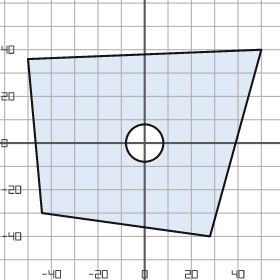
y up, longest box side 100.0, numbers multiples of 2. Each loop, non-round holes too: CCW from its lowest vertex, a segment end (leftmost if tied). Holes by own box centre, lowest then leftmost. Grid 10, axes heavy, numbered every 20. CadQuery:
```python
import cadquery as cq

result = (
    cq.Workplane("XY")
    .moveTo(28.0, -40.0)
    .lineTo(50.0, 40.0)
    .lineTo(-50.0, 36.0)
    .lineTo(-44.0, -30.0)
    .close()
    .moveTo(0.0, 0.0)
    .circle(8.0)
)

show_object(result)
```